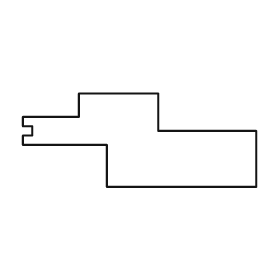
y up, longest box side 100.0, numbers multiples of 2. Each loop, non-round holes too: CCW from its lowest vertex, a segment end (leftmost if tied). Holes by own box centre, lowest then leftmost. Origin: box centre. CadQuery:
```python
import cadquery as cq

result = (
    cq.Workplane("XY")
    .moveTo(-14.0, -20.0)
    .lineTo(50.0, -20.0)
    .lineTo(50.0, 4.0)
    .lineTo(8.0, 4.0)
    .lineTo(8.0, 20.0)
    .lineTo(-26.0, 20.0)
    .lineTo(-26.0, 10.0)
    .lineTo(-50.0, 10.0)
    .lineTo(-50.0, 6.0)
    .lineTo(-46.0, 6.0)
    .lineTo(-46.0, 2.0)
    .lineTo(-50.0, 2.0)
    .lineTo(-50.0, -2.0)
    .lineTo(-14.0, -2.0)
    .close()
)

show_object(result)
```